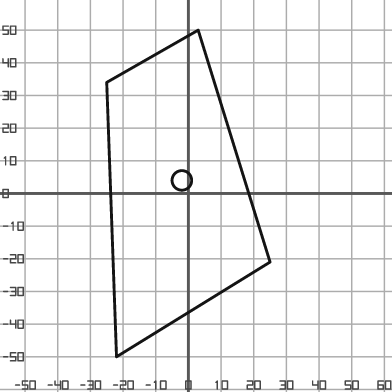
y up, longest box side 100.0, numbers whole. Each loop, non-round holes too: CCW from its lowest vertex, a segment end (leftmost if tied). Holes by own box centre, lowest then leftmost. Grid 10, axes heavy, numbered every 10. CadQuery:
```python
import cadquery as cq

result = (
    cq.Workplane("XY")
    .moveTo(-22.0, -50.0)
    .lineTo(25.0, -21.0)
    .lineTo(3.0, 50.0)
    .lineTo(-25.0, 34.0)
    .close()
    .moveTo(-2.0, 4.0)
    .circle(3.0)
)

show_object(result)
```